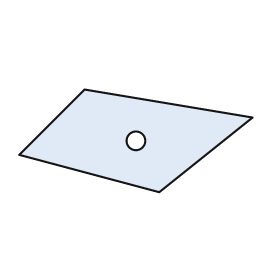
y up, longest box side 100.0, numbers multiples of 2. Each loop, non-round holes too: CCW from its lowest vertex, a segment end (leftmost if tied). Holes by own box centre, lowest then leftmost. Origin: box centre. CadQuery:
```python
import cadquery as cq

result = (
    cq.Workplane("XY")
    .moveTo(10.0, -22.0)
    .lineTo(50.0, 10.0)
    .lineTo(-22.0, 22.0)
    .lineTo(-50.0, -6.0)
    .close()
    .moveTo(0.0, 0.0)
    .circle(4.0)
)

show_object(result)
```